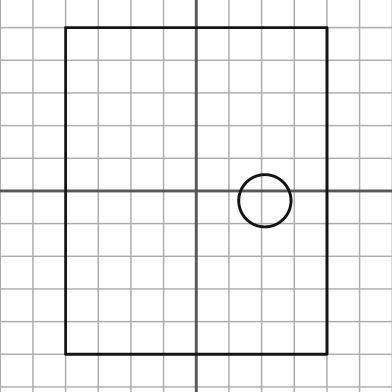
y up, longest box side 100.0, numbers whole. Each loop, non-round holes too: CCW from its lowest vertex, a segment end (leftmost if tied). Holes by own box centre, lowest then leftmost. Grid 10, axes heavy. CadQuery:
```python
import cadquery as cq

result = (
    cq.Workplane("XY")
    .moveTo(-40.0, -50.0)
    .lineTo(40.0, -50.0)
    .lineTo(40.0, 50.0)
    .lineTo(-40.0, 50.0)
    .close()
    .moveTo(21.0, -3.0)
    .circle(8.0)
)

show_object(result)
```